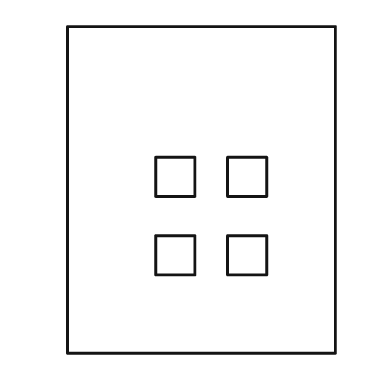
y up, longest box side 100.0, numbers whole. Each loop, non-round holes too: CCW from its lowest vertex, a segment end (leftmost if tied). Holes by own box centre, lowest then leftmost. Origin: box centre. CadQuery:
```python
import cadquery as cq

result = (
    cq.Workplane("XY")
    .moveTo(-41.0, -50.0)
    .lineTo(41.0, -50.0)
    .lineTo(41.0, 50.0)
    .lineTo(-41.0, 50.0)
    .close()
    .moveTo(-14.0, -26.0)
    .lineTo(-2.0, -26.0)
    .lineTo(-2.0, -14.0)
    .lineTo(-14.0, -14.0)
    .close()
    .moveTo(8.0, -26.0)
    .lineTo(20.0, -26.0)
    .lineTo(20.0, -14.0)
    .lineTo(8.0, -14.0)
    .close()
    .moveTo(-14.0, -2.0)
    .lineTo(-2.0, -2.0)
    .lineTo(-2.0, 10.0)
    .lineTo(-14.0, 10.0)
    .close()
    .moveTo(8.0, -2.0)
    .lineTo(20.0, -2.0)
    .lineTo(20.0, 10.0)
    .lineTo(8.0, 10.0)
    .close()
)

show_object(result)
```